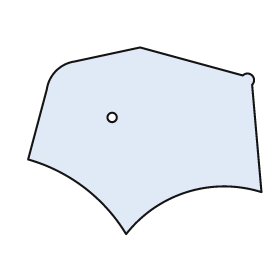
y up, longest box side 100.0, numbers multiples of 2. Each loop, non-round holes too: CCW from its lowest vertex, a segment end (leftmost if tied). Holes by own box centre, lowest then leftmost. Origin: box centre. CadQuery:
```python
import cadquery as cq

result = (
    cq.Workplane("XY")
    .moveTo(-8.0, -40.0)
    .threePointArc((18.0, -22.0), (50.0, -22.0))
    .lineTo(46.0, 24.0)
    .threePointArc((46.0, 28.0), (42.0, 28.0))
    .lineTo(-2.0, 40.0)
    .lineTo(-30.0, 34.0)
    .threePointArc((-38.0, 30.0), (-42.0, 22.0))
    .lineTo(-50.0, -8.0)
    .threePointArc((-26.0, -20.0), (-8.0, -40.0))
    .close()
    .moveTo(-14.0, 10.0)
    .circle(2.0)
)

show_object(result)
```